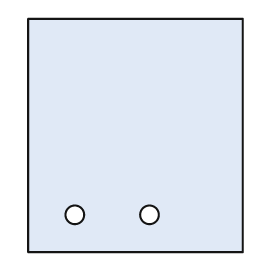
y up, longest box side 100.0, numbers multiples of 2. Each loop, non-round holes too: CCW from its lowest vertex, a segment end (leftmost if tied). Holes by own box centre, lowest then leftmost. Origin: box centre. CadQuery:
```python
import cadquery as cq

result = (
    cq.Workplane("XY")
    .moveTo(-46.0, -50.0)
    .lineTo(46.0, -50.0)
    .lineTo(46.0, 50.0)
    .lineTo(-46.0, 50.0)
    .close()
    .moveTo(-26.0, -34.0)
    .circle(4.0)
    .moveTo(6.0, -34.0)
    .circle(4.0)
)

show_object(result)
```